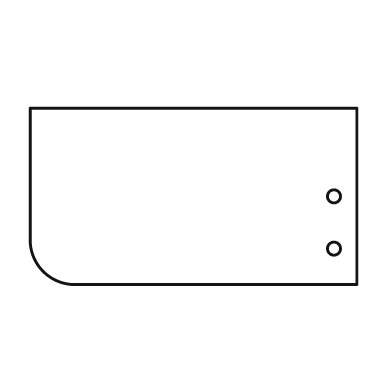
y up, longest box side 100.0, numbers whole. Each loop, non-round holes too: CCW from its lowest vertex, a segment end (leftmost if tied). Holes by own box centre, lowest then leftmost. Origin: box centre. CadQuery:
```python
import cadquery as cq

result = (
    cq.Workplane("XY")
    .moveTo(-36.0, -27.0)
    .lineTo(50.0, -27.0)
    .lineTo(50.0, 27.0)
    .lineTo(-50.0, 27.0)
    .lineTo(-50.0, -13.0)
    .threePointArc((-46.0, -23.0), (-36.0, -27.0))
    .close()
    .moveTo(43.0, -16.0)
    .circle(2.0)
    .moveTo(43.0, 0.0)
    .circle(2.0)
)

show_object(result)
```